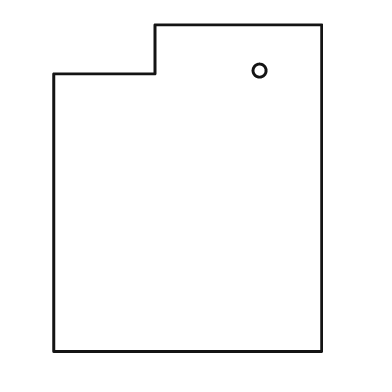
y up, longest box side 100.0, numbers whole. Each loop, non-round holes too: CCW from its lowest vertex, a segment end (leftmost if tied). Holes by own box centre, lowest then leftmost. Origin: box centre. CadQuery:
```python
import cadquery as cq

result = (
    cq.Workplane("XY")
    .moveTo(-41.0, -50.0)
    .lineTo(41.0, -50.0)
    .lineTo(41.0, 50.0)
    .lineTo(-10.0, 50.0)
    .lineTo(-10.0, 35.0)
    .lineTo(-41.0, 35.0)
    .close()
    .moveTo(22.0, 36.0)
    .circle(2.0)
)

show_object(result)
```